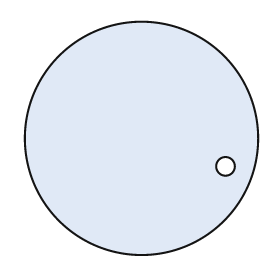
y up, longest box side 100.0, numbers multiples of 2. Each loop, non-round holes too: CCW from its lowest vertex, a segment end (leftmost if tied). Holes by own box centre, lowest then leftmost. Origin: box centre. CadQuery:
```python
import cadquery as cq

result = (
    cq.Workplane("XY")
    .moveTo(0.0, 0.0)
    .circle(50.0)
    .moveTo(36.0, -12.0)
    .circle(4.0)
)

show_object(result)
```